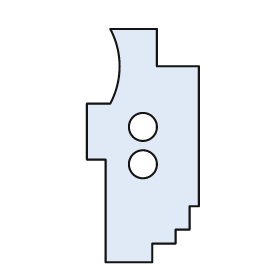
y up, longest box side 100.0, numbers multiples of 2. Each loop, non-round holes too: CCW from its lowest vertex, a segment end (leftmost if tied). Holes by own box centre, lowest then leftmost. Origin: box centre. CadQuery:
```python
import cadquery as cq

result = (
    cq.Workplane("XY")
    .moveTo(-16.0, -50.0)
    .lineTo(4.0, -50.0)
    .lineTo(4.0, -42.0)
    .lineTo(14.0, -42.0)
    .lineTo(14.0, -36.0)
    .lineTo(20.0, -36.0)
    .lineTo(20.0, -26.0)
    .lineTo(24.0, -26.0)
    .lineTo(24.0, 34.0)
    .lineTo(6.0, 34.0)
    .lineTo(6.0, 50.0)
    .lineTo(-14.0, 50.0)
    .threePointArc((-10.0, 34.0), (-14.0, 18.0))
    .lineTo(-24.0, 18.0)
    .lineTo(-24.0, -6.0)
    .lineTo(-16.0, -6.0)
    .close()
    .moveTo(0.0, -8.0)
    .circle(6.0)
    .moveTo(0.0, 8.0)
    .circle(6.0)
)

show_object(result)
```